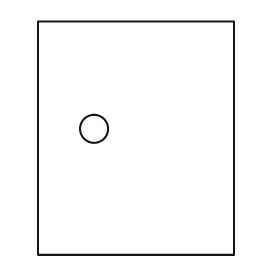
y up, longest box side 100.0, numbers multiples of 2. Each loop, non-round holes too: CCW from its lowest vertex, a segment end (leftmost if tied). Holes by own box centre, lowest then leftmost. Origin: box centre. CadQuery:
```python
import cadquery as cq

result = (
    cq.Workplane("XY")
    .moveTo(-42.0, -50.0)
    .lineTo(42.0, -50.0)
    .lineTo(42.0, 50.0)
    .lineTo(-42.0, 50.0)
    .close()
    .moveTo(-18.0, 4.0)
    .circle(6.0)
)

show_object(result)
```